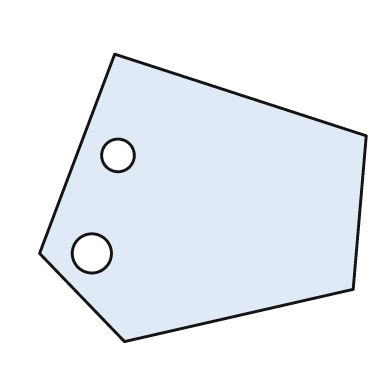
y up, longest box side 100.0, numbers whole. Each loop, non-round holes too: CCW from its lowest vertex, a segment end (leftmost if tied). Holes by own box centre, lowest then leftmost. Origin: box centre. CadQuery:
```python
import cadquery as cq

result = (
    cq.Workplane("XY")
    .moveTo(-24.0, -44.0)
    .lineTo(46.0, -28.0)
    .lineTo(50.0, 19.0)
    .lineTo(-27.0, 44.0)
    .lineTo(-50.0, -17.0)
    .close()
    .moveTo(-34.0, -17.0)
    .circle(6.0)
    .moveTo(-26.0, 13.0)
    .circle(5.0)
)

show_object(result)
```